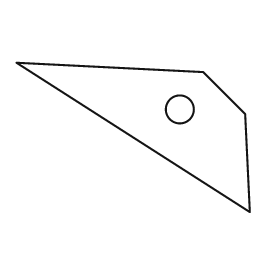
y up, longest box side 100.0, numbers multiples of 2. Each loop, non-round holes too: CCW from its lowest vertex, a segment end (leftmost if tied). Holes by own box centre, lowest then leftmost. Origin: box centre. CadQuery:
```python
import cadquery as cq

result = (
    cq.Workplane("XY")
    .moveTo(50.0, -32.0)
    .lineTo(48.0, 10.0)
    .lineTo(30.0, 28.0)
    .lineTo(-50.0, 32.0)
    .close()
    .moveTo(20.0, 12.0)
    .circle(6.0)
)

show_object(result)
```